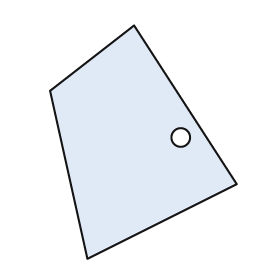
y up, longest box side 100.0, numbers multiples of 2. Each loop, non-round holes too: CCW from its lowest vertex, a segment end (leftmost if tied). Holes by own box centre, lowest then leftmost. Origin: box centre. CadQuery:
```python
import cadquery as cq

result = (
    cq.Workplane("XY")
    .moveTo(-24.0, -50.0)
    .lineTo(40.0, -18.0)
    .lineTo(-4.0, 50.0)
    .lineTo(-40.0, 22.0)
    .close()
    .moveTo(16.0, 2.0)
    .circle(4.0)
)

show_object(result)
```